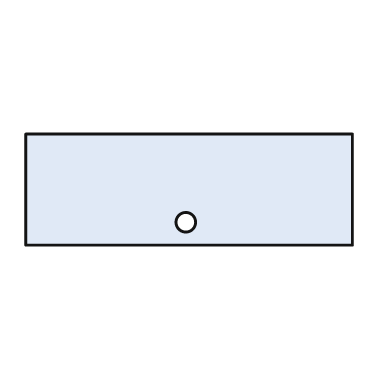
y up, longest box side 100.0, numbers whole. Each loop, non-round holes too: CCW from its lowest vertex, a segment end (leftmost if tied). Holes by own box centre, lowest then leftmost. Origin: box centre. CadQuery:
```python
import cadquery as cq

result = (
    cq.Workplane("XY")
    .moveTo(-50.0, -17.0)
    .lineTo(50.0, -17.0)
    .lineTo(50.0, 17.0)
    .lineTo(-50.0, 17.0)
    .close()
    .moveTo(-1.0, -10.0)
    .circle(3.0)
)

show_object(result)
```